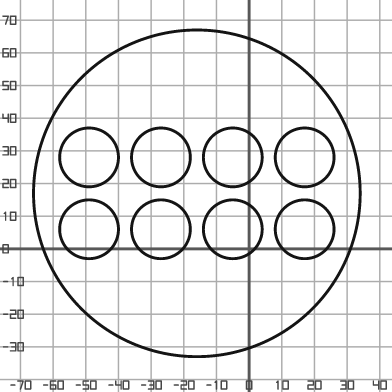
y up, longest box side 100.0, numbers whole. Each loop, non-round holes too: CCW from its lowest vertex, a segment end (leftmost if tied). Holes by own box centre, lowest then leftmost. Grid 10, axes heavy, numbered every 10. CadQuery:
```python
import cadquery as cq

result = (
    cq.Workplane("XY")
    .moveTo(-16.0, 17.0)
    .circle(50.0)
    .moveTo(-49.0, 6.0)
    .circle(9.0)
    .moveTo(-27.0, 6.0)
    .circle(9.0)
    .moveTo(-5.0, 6.0)
    .circle(9.0)
    .moveTo(17.0, 6.0)
    .circle(9.0)
    .moveTo(-49.0, 28.0)
    .circle(9.0)
    .moveTo(-27.0, 28.0)
    .circle(9.0)
    .moveTo(-5.0, 28.0)
    .circle(9.0)
    .moveTo(17.0, 28.0)
    .circle(9.0)
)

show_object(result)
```